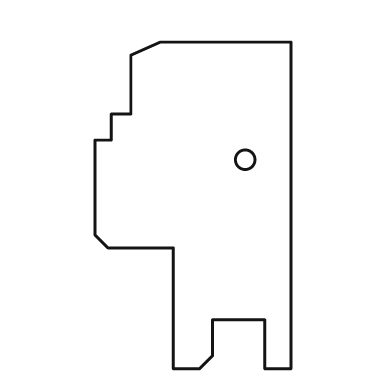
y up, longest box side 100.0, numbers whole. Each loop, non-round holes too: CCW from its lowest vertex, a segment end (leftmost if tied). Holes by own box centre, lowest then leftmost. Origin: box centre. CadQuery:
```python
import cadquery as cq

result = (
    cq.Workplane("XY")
    .moveTo(-6.0, -50.0)
    .lineTo(2.0, -50.0)
    .lineTo(6.0, -46.0)
    .lineTo(6.0, -35.0)
    .lineTo(22.0, -35.0)
    .lineTo(22.0, -50.0)
    .lineTo(30.0, -50.0)
    .lineTo(30.0, 50.0)
    .lineTo(-10.0, 50.0)
    .lineTo(-19.0, 46.0)
    .lineTo(-19.0, 28.0)
    .lineTo(-25.0, 28.0)
    .lineTo(-25.0, 20.0)
    .lineTo(-30.0, 20.0)
    .lineTo(-30.0, -9.0)
    .lineTo(-26.0, -13.0)
    .lineTo(-6.0, -13.0)
    .close()
    .moveTo(16.0, 14.0)
    .circle(3.0)
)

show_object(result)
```